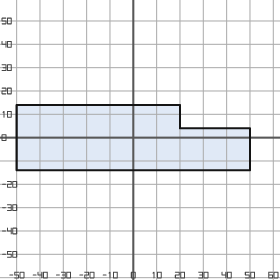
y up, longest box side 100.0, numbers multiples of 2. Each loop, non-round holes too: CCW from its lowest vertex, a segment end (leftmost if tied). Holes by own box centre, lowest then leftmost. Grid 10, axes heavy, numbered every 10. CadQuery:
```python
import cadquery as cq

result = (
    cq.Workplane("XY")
    .moveTo(-50.0, -14.0)
    .lineTo(50.0, -14.0)
    .lineTo(50.0, 4.0)
    .lineTo(20.0, 4.0)
    .lineTo(20.0, 14.0)
    .lineTo(-50.0, 14.0)
    .close()
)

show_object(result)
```